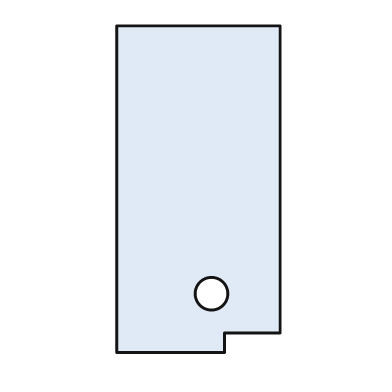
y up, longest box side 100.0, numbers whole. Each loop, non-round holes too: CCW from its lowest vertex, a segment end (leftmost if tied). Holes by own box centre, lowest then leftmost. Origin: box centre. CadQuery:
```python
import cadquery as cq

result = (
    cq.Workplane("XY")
    .moveTo(-25.0, -50.0)
    .lineTo(8.0, -50.0)
    .lineTo(8.0, -44.0)
    .lineTo(25.0, -44.0)
    .lineTo(25.0, 50.0)
    .lineTo(-25.0, 50.0)
    .close()
    .moveTo(4.0, -32.0)
    .circle(5.0)
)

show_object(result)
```